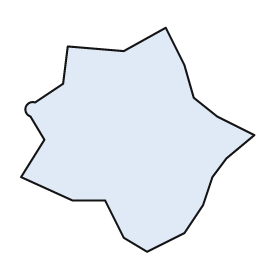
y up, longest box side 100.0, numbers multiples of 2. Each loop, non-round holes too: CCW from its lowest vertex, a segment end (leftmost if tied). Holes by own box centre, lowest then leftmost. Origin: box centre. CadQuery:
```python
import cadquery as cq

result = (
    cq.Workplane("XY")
    .moveTo(4.0, -48.0)
    .lineTo(20.0, -40.0)
    .lineTo(28.0, -28.0)
    .lineTo(32.0, -16.0)
    .lineTo(38.0, -8.0)
    .lineTo(50.0, 2.0)
    .lineTo(34.0, 10.0)
    .lineTo(24.0, 18.0)
    .lineTo(20.0, 32.0)
    .lineTo(12.0, 48.0)
    .lineTo(-6.0, 38.0)
    .lineTo(-30.0, 40.0)
    .lineTo(-32.0, 24.0)
    .lineTo(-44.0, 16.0)
    .threePointArc((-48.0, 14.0), (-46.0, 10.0))
    .lineTo(-40.0, 0.0)
    .lineTo(-50.0, -16.0)
    .lineTo(-28.0, -26.0)
    .lineTo(-14.0, -26.0)
    .lineTo(-6.0, -42.0)
    .close()
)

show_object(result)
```